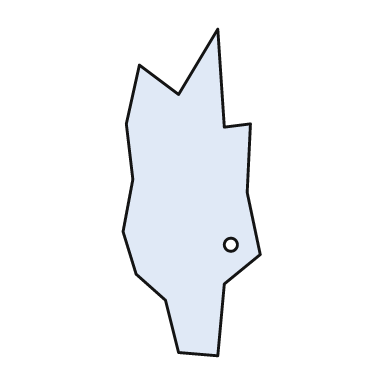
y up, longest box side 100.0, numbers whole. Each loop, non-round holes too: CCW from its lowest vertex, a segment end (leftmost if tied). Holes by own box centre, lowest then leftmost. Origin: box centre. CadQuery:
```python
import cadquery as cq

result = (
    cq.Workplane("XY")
    .moveTo(8.0, -50.0)
    .lineTo(10.0, -28.0)
    .lineTo(21.0, -19.0)
    .lineTo(17.0, 0.0)
    .lineTo(18.0, 21.0)
    .lineTo(10.0, 20.0)
    .lineTo(8.0, 50.0)
    .lineTo(-4.0, 30.0)
    .lineTo(-16.0, 39.0)
    .lineTo(-20.0, 21.0)
    .lineTo(-18.0, 4.0)
    .lineTo(-21.0, -12.0)
    .lineTo(-17.0, -25.0)
    .lineTo(-8.0, -33.0)
    .lineTo(-4.0, -49.0)
    .close()
    .moveTo(12.0, -16.0)
    .circle(2.0)
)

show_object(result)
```